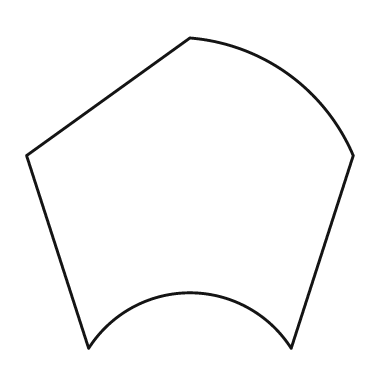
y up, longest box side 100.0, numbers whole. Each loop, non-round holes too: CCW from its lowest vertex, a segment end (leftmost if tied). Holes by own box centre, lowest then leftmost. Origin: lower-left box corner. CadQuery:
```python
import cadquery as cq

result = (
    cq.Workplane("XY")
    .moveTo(19.0, 0.0)
    .threePointArc((50.0, 17.0), (81.0, 0.0))
    .lineTo(100.0, 59.0)
    .threePointArc((80.0, 84.0), (50.0, 95.0))
    .lineTo(0.0, 59.0)
    .close()
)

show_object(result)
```